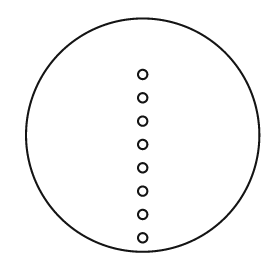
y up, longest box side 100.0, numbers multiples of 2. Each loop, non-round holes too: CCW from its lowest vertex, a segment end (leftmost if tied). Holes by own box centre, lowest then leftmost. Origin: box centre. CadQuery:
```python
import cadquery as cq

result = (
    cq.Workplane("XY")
    .moveTo(0.0, 0.0)
    .circle(50.0)
    .moveTo(0.0, -44.0)
    .circle(2.0)
    .moveTo(0.0, -34.0)
    .circle(2.0)
    .moveTo(0.0, -24.0)
    .circle(2.0)
    .moveTo(0.0, -14.0)
    .circle(2.0)
    .moveTo(0.0, -4.0)
    .circle(2.0)
    .moveTo(0.0, 6.0)
    .circle(2.0)
    .moveTo(0.0, 16.0)
    .circle(2.0)
    .moveTo(0.0, 26.0)
    .circle(2.0)
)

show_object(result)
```